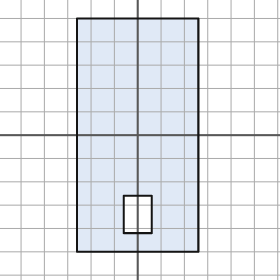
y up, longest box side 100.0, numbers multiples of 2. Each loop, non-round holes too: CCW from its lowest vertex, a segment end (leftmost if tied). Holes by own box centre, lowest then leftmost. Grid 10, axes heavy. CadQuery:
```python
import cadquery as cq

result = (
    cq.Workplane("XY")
    .moveTo(-26.0, -50.0)
    .lineTo(26.0, -50.0)
    .lineTo(26.0, 50.0)
    .lineTo(-26.0, 50.0)
    .close()
    .moveTo(-6.0, -42.0)
    .lineTo(6.0, -42.0)
    .lineTo(6.0, -26.0)
    .lineTo(-6.0, -26.0)
    .close()
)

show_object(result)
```